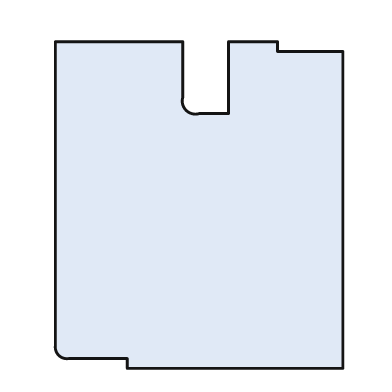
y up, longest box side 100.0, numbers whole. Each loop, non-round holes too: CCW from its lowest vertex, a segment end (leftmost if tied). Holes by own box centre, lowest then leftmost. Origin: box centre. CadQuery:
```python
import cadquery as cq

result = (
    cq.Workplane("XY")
    .moveTo(-22.0, -50.0)
    .lineTo(44.0, -50.0)
    .lineTo(44.0, 47.0)
    .lineTo(24.0, 47.0)
    .lineTo(24.0, 50.0)
    .lineTo(9.0, 50.0)
    .lineTo(9.0, 28.0)
    .lineTo(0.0, 28.0)
    .threePointArc((-4.0, 29.0), (-5.0, 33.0))
    .lineTo(-5.0, 50.0)
    .lineTo(-44.0, 50.0)
    .lineTo(-44.0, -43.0)
    .threePointArc((-43.0, -46.0), (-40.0, -47.0))
    .lineTo(-22.0, -47.0)
    .close()
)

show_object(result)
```